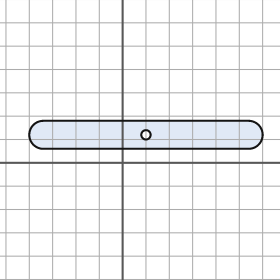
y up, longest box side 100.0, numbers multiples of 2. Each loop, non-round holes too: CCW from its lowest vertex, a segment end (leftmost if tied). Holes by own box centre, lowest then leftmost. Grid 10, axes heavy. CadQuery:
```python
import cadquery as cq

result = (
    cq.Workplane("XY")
    .moveTo(-34.0, 6.0)
    .lineTo(54.0, 6.0)
    .threePointArc((60.0, 12.0), (54.0, 18.0))
    .lineTo(-34.0, 18.0)
    .threePointArc((-40.0, 12.0), (-34.0, 6.0))
    .close()
    .moveTo(10.0, 12.0)
    .circle(2.0)
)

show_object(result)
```